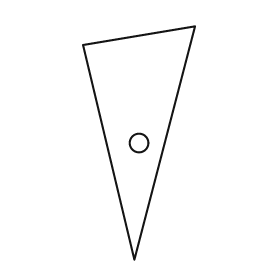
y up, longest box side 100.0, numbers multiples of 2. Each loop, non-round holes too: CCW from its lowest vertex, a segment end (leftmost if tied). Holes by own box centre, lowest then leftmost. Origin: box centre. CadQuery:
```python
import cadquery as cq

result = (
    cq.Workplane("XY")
    .moveTo(-2.0, -50.0)
    .lineTo(24.0, 50.0)
    .lineTo(-24.0, 42.0)
    .close()
    .moveTo(0.0, 0.0)
    .circle(4.0)
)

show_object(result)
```